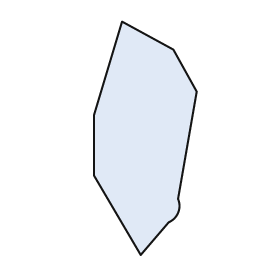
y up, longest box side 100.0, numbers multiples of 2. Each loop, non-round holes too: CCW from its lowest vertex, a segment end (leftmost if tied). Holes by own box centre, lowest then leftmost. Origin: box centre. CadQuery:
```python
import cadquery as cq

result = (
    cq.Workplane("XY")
    .moveTo(-2.0, -50.0)
    .lineTo(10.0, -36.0)
    .threePointArc((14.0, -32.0), (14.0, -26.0))
    .lineTo(22.0, 20.0)
    .lineTo(12.0, 38.0)
    .lineTo(-10.0, 50.0)
    .lineTo(-22.0, 10.0)
    .lineTo(-22.0, -16.0)
    .close()
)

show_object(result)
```